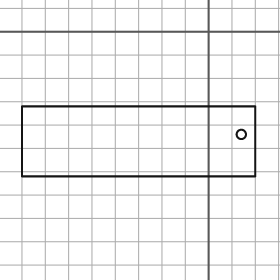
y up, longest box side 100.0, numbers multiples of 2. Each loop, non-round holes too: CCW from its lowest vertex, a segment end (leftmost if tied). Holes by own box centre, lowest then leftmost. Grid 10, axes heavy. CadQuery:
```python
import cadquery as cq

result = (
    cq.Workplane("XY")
    .moveTo(-80.0, -62.0)
    .lineTo(20.0, -62.0)
    .lineTo(20.0, -32.0)
    .lineTo(-80.0, -32.0)
    .close()
    .moveTo(14.0, -44.0)
    .circle(2.0)
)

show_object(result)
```